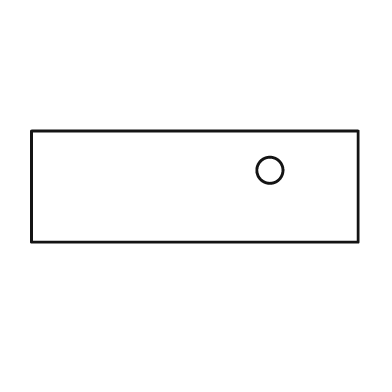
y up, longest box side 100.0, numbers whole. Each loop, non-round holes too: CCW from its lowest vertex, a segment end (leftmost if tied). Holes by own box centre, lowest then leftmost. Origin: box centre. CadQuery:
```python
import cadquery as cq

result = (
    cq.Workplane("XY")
    .moveTo(-50.0, -17.0)
    .lineTo(50.0, -17.0)
    .lineTo(50.0, 17.0)
    .lineTo(-50.0, 17.0)
    .close()
    .moveTo(23.0, 5.0)
    .circle(4.0)
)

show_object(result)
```